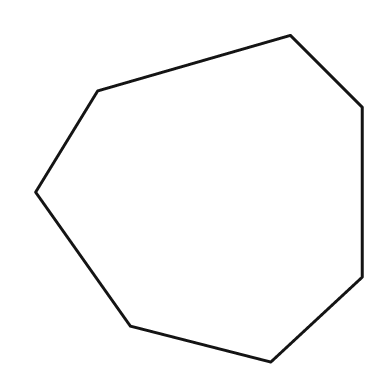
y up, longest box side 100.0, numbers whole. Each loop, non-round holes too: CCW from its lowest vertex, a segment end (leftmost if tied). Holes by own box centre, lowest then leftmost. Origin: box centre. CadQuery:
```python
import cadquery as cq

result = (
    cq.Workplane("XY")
    .moveTo(22.0, -50.0)
    .lineTo(50.0, -24.0)
    .lineTo(50.0, 28.0)
    .lineTo(28.0, 50.0)
    .lineTo(-31.0, 33.0)
    .lineTo(-50.0, 2.0)
    .lineTo(-21.0, -39.0)
    .close()
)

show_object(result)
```